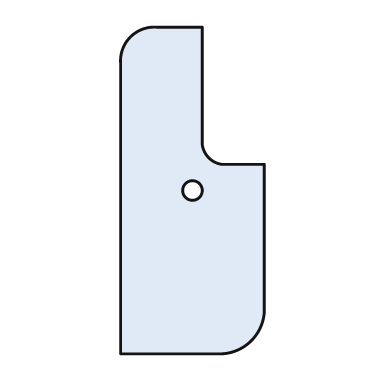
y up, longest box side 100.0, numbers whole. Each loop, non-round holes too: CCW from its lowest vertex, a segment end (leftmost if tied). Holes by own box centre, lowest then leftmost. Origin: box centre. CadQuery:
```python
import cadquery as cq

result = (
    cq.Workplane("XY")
    .moveTo(-22.0, -50.0)
    .lineTo(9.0, -50.0)
    .threePointArc((18.0, -46.0), (22.0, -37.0))
    .lineTo(22.0, 8.0)
    .lineTo(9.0, 8.0)
    .threePointArc((5.0, 10.0), (3.0, 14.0))
    .lineTo(3.0, 50.0)
    .lineTo(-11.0, 50.0)
    .threePointArc((-19.0, 47.0), (-22.0, 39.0))
    .close()
    .moveTo(0.0, 0.0)
    .circle(3.0)
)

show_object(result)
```